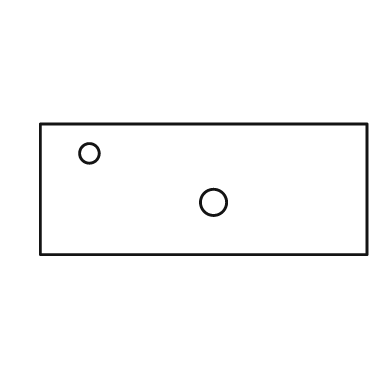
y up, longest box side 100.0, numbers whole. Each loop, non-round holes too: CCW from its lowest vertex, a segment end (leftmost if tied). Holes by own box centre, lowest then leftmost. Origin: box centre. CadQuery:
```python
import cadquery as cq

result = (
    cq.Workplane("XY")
    .moveTo(-50.0, -20.0)
    .lineTo(50.0, -20.0)
    .lineTo(50.0, 20.0)
    .lineTo(-50.0, 20.0)
    .close()
    .moveTo(3.0, -4.0)
    .circle(4.0)
    .moveTo(-35.0, 11.0)
    .circle(3.0)
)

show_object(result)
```